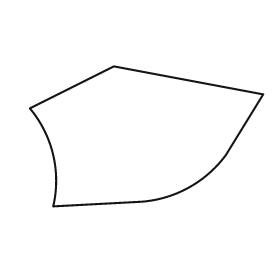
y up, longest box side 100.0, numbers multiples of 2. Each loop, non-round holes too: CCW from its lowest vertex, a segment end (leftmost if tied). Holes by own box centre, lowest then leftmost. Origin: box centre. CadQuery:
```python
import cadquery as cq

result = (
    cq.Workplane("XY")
    .moveTo(-40.0, -30.0)
    .lineTo(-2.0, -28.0)
    .threePointArc((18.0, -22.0), (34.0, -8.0))
    .lineTo(50.0, 18.0)
    .lineTo(-14.0, 30.0)
    .lineTo(-50.0, 12.0)
    .threePointArc((-40.0, -8.0), (-40.0, -30.0))
    .close()
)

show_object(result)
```